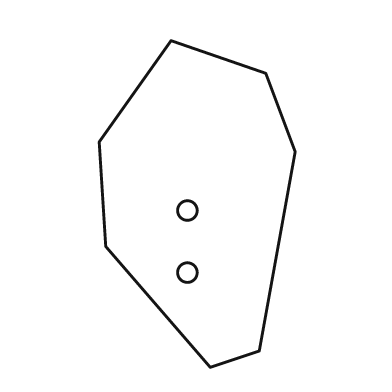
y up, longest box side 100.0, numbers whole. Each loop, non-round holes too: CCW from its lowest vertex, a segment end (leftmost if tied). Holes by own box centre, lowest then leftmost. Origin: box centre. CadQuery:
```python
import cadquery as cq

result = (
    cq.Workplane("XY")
    .moveTo(4.0, -50.0)
    .lineTo(19.0, -45.0)
    .lineTo(30.0, 16.0)
    .lineTo(21.0, 40.0)
    .lineTo(-8.0, 50.0)
    .lineTo(-30.0, 19.0)
    .lineTo(-28.0, -13.0)
    .close()
    .moveTo(-3.0, -21.0)
    .circle(3.0)
    .moveTo(-3.0, -2.0)
    .circle(3.0)
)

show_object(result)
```